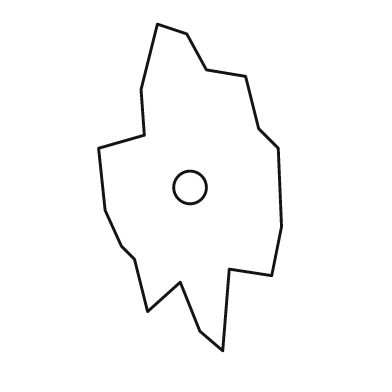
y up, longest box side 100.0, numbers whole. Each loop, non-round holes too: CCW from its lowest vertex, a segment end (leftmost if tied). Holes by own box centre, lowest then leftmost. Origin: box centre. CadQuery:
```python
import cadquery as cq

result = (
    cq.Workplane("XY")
    .moveTo(10.0, -50.0)
    .lineTo(12.0, -25.0)
    .lineTo(25.0, -27.0)
    .lineTo(28.0, -12.0)
    .lineTo(27.0, 12.0)
    .lineTo(21.0, 18.0)
    .lineTo(17.0, 34.0)
    .lineTo(5.0, 36.0)
    .lineTo(-1.0, 47.0)
    .lineTo(-10.0, 50.0)
    .lineTo(-15.0, 30.0)
    .lineTo(-14.0, 16.0)
    .lineTo(-28.0, 12.0)
    .lineTo(-26.0, -7.0)
    .lineTo(-21.0, -18.0)
    .lineTo(-17.0, -22.0)
    .lineTo(-13.0, -38.0)
    .lineTo(-3.0, -29.0)
    .lineTo(3.0, -44.0)
    .close()
    .moveTo(0.0, 0.0)
    .circle(5.0)
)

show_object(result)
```